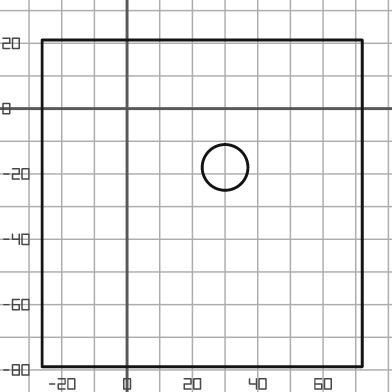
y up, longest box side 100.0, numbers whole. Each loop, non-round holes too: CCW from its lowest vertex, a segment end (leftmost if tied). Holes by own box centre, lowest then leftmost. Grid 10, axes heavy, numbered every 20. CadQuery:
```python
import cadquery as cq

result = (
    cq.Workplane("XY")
    .moveTo(-26.0, -79.0)
    .lineTo(72.0, -79.0)
    .lineTo(72.0, 21.0)
    .lineTo(-26.0, 21.0)
    .close()
    .moveTo(30.0, -18.0)
    .circle(7.0)
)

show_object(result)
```